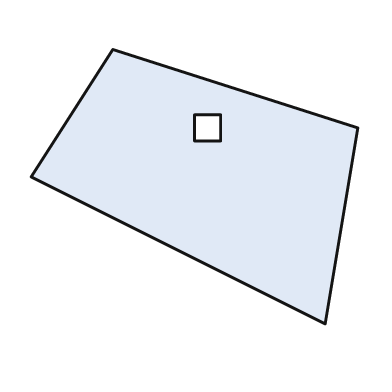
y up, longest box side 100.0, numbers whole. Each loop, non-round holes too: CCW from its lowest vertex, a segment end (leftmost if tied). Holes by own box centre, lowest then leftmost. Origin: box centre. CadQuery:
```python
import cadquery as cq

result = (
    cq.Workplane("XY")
    .moveTo(40.0, -42.0)
    .lineTo(50.0, 18.0)
    .lineTo(-25.0, 42.0)
    .lineTo(-50.0, 3.0)
    .close()
    .moveTo(0.0, 14.0)
    .lineTo(8.0, 14.0)
    .lineTo(8.0, 22.0)
    .lineTo(0.0, 22.0)
    .close()
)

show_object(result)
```